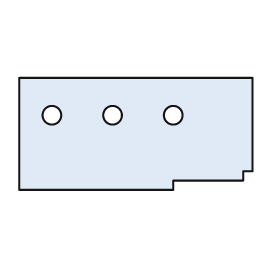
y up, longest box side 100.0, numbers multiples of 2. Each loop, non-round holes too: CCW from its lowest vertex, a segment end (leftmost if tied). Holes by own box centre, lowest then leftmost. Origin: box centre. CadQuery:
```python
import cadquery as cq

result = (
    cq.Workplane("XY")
    .moveTo(-50.0, -24.0)
    .lineTo(16.0, -24.0)
    .lineTo(16.0, -20.0)
    .lineTo(46.0, -20.0)
    .lineTo(46.0, -16.0)
    .lineTo(50.0, -16.0)
    .lineTo(50.0, 24.0)
    .lineTo(-50.0, 24.0)
    .close()
    .moveTo(-36.0, 8.0)
    .circle(4.0)
    .moveTo(-10.0, 8.0)
    .circle(4.0)
    .moveTo(16.0, 8.0)
    .circle(4.0)
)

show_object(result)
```